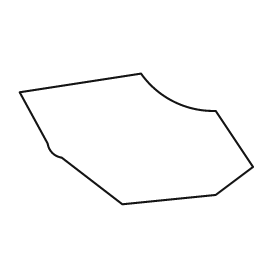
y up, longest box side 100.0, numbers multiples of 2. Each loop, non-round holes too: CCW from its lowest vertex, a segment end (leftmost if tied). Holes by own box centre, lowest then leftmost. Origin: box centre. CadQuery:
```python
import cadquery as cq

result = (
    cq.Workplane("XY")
    .moveTo(-6.0, -28.0)
    .lineTo(34.0, -24.0)
    .lineTo(50.0, -12.0)
    .lineTo(34.0, 12.0)
    .threePointArc((16.0, 16.0), (2.0, 28.0))
    .lineTo(-50.0, 20.0)
    .lineTo(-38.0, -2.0)
    .threePointArc((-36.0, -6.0), (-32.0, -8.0))
    .close()
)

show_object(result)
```